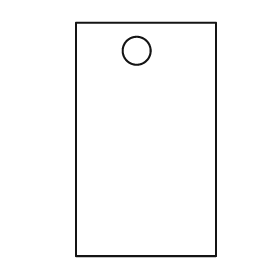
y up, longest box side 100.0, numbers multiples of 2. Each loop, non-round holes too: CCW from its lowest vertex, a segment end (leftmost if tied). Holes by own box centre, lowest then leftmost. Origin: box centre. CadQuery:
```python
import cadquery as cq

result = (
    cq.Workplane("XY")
    .moveTo(-30.0, -50.0)
    .lineTo(30.0, -50.0)
    .lineTo(30.0, 50.0)
    .lineTo(-30.0, 50.0)
    .close()
    .moveTo(-4.0, 38.0)
    .circle(6.0)
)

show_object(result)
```